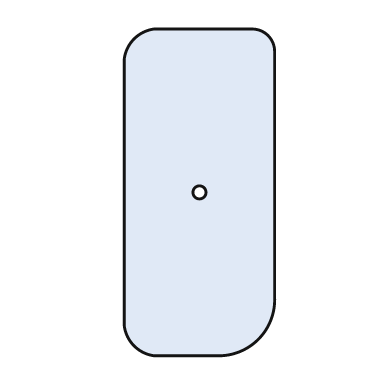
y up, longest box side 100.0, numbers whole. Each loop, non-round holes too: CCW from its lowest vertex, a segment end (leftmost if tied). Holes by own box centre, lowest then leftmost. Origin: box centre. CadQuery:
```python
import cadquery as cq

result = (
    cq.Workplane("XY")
    .moveTo(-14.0, -50.0)
    .lineTo(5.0, -50.0)
    .threePointArc((18.0, -45.0), (23.0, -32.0))
    .lineTo(23.0, 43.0)
    .threePointArc((21.0, 48.0), (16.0, 50.0))
    .lineTo(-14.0, 50.0)
    .threePointArc((-20.0, 47.0), (-23.0, 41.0))
    .lineTo(-23.0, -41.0)
    .threePointArc((-20.0, -47.0), (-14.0, -50.0))
    .close()
    .moveTo(0.0, 0.0)
    .circle(2.0)
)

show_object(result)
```